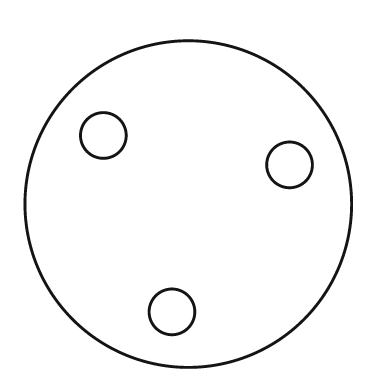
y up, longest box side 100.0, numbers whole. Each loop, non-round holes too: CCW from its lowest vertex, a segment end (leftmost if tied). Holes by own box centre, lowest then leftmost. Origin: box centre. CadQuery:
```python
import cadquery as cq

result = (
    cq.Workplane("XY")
    .moveTo(0.0, 0.0)
    .circle(50.0)
    .moveTo(-5.0, -33.0)
    .circle(7.0)
    .moveTo(31.0, 12.0)
    .circle(7.0)
    .moveTo(-26.0, 21.0)
    .circle(7.0)
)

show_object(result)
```